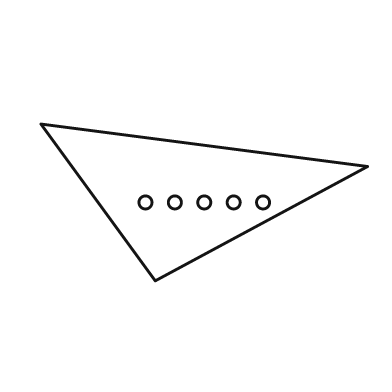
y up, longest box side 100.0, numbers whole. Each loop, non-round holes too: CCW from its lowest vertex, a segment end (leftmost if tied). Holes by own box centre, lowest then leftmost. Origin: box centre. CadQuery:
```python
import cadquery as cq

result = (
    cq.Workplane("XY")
    .moveTo(-15.0, -24.0)
    .lineTo(50.0, 11.0)
    .lineTo(-50.0, 24.0)
    .close()
    .moveTo(-18.0, 0.0)
    .circle(2.0)
    .moveTo(-9.0, 0.0)
    .circle(2.0)
    .moveTo(0.0, 0.0)
    .circle(2.0)
    .moveTo(9.0, 0.0)
    .circle(2.0)
    .moveTo(18.0, 0.0)
    .circle(2.0)
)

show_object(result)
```